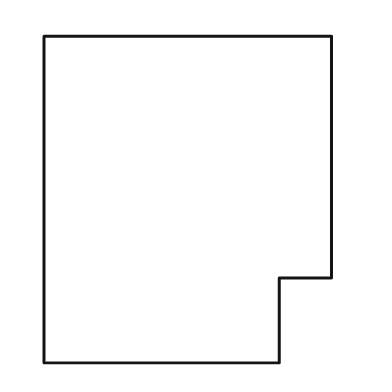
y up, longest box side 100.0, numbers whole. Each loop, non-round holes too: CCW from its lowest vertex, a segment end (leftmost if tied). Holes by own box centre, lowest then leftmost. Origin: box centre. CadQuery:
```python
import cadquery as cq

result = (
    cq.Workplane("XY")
    .moveTo(-44.0, -50.0)
    .lineTo(28.0, -50.0)
    .lineTo(28.0, -24.0)
    .lineTo(44.0, -24.0)
    .lineTo(44.0, 50.0)
    .lineTo(-44.0, 50.0)
    .close()
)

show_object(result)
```